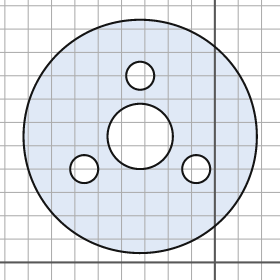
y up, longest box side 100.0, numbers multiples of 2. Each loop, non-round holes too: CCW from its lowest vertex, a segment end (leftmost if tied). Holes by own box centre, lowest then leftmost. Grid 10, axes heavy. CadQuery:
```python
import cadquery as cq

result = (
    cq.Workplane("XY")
    .moveTo(-32.0, 54.0)
    .circle(50.0)
    .moveTo(-56.0, 40.0)
    .circle(6.0)
    .moveTo(-8.0, 40.0)
    .circle(6.0)
    .moveTo(-32.0, 54.0)
    .circle(14.0)
    .moveTo(-32.0, 80.0)
    .circle(6.0)
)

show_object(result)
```